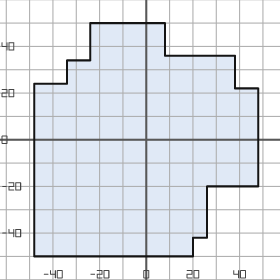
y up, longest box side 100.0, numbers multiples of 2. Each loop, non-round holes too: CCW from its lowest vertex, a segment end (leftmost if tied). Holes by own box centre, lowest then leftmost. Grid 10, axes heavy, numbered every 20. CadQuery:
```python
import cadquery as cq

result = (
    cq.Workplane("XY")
    .moveTo(-48.0, -50.0)
    .lineTo(20.0, -50.0)
    .lineTo(20.0, -42.0)
    .lineTo(26.0, -42.0)
    .lineTo(26.0, -20.0)
    .lineTo(48.0, -20.0)
    .lineTo(48.0, 22.0)
    .lineTo(38.0, 22.0)
    .lineTo(38.0, 36.0)
    .lineTo(8.0, 36.0)
    .lineTo(8.0, 50.0)
    .lineTo(-24.0, 50.0)
    .lineTo(-24.0, 34.0)
    .lineTo(-34.0, 34.0)
    .lineTo(-34.0, 24.0)
    .lineTo(-48.0, 24.0)
    .close()
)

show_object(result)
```